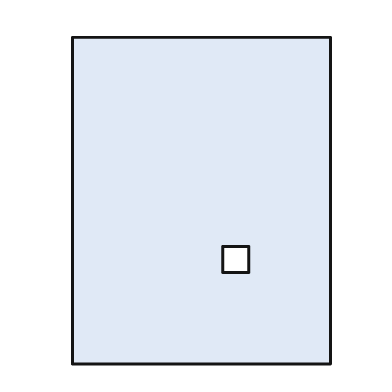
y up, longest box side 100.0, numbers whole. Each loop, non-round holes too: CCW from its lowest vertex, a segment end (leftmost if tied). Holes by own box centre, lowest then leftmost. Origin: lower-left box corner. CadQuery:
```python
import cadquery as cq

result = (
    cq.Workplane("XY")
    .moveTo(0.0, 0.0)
    .lineTo(79.0, 0.0)
    .lineTo(79.0, 100.0)
    .lineTo(0.0, 100.0)
    .close()
    .moveTo(46.0, 28.0)
    .lineTo(54.0, 28.0)
    .lineTo(54.0, 36.0)
    .lineTo(46.0, 36.0)
    .close()
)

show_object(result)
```